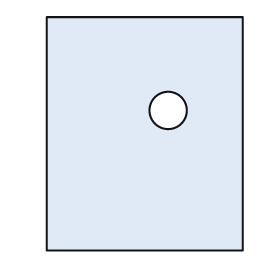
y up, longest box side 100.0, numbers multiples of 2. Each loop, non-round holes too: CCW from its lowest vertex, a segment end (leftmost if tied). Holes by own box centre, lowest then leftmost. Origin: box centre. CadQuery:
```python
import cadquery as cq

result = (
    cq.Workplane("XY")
    .moveTo(-42.0, -50.0)
    .lineTo(42.0, -50.0)
    .lineTo(42.0, 50.0)
    .lineTo(-42.0, 50.0)
    .close()
    .moveTo(10.0, 10.0)
    .circle(8.0)
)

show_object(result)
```